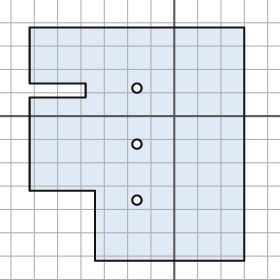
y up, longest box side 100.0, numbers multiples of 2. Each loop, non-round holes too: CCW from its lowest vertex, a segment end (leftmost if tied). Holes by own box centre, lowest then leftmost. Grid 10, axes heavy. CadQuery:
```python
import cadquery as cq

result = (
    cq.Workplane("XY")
    .moveTo(-34.0, -62.0)
    .lineTo(30.0, -62.0)
    .lineTo(30.0, 38.0)
    .lineTo(-62.0, 38.0)
    .lineTo(-62.0, 14.0)
    .lineTo(-38.0, 14.0)
    .lineTo(-38.0, 8.0)
    .lineTo(-62.0, 8.0)
    .lineTo(-62.0, -32.0)
    .lineTo(-34.0, -32.0)
    .close()
    .moveTo(-16.0, -36.0)
    .circle(2.0)
    .moveTo(-16.0, -12.0)
    .circle(2.0)
    .moveTo(-16.0, 12.0)
    .circle(2.0)
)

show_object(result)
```